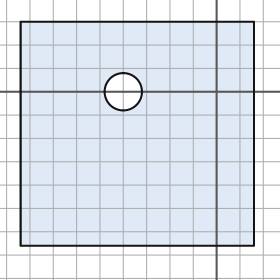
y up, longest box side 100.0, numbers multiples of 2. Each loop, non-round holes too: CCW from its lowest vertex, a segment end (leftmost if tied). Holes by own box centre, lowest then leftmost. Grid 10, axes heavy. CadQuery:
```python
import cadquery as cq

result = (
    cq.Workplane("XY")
    .moveTo(-84.0, -66.0)
    .lineTo(16.0, -66.0)
    .lineTo(16.0, 30.0)
    .lineTo(-84.0, 30.0)
    .close()
    .moveTo(-40.0, 0.0)
    .circle(8.0)
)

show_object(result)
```